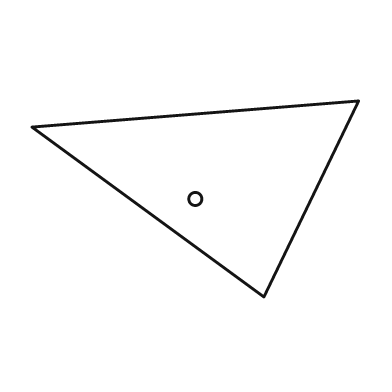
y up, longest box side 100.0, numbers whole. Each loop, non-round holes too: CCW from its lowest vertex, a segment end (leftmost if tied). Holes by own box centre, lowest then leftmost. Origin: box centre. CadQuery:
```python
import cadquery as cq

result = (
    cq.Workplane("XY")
    .moveTo(21.0, -30.0)
    .lineTo(50.0, 30.0)
    .lineTo(-50.0, 22.0)
    .close()
    .moveTo(0.0, 0.0)
    .circle(2.0)
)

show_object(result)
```